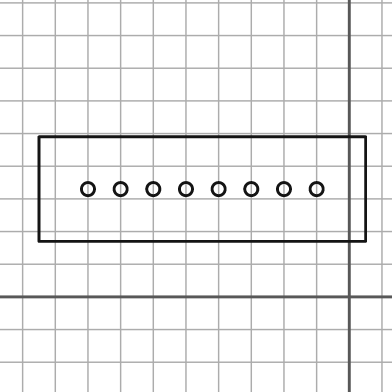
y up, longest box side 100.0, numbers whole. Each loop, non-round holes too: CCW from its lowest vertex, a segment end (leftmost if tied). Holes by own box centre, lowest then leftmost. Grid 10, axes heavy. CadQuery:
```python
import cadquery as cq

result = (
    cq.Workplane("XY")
    .moveTo(-95.0, 17.0)
    .lineTo(5.0, 17.0)
    .lineTo(5.0, 49.0)
    .lineTo(-95.0, 49.0)
    .close()
    .moveTo(-80.0, 33.0)
    .circle(2.0)
    .moveTo(-70.0, 33.0)
    .circle(2.0)
    .moveTo(-60.0, 33.0)
    .circle(2.0)
    .moveTo(-50.0, 33.0)
    .circle(2.0)
    .moveTo(-40.0, 33.0)
    .circle(2.0)
    .moveTo(-30.0, 33.0)
    .circle(2.0)
    .moveTo(-20.0, 33.0)
    .circle(2.0)
    .moveTo(-10.0, 33.0)
    .circle(2.0)
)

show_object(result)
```